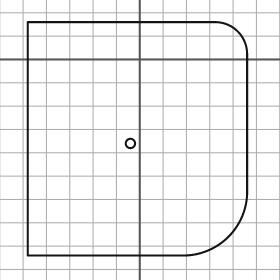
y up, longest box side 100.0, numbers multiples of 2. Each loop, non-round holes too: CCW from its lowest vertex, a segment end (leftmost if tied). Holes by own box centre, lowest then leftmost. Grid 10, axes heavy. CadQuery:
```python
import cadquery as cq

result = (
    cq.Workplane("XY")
    .moveTo(-48.0, -84.0)
    .lineTo(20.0, -84.0)
    .threePointArc((38.0, -76.0), (46.0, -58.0))
    .lineTo(46.0, 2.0)
    .threePointArc((42.0, 12.0), (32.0, 16.0))
    .lineTo(-48.0, 16.0)
    .close()
    .moveTo(-4.0, -36.0)
    .circle(2.0)
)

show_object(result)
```